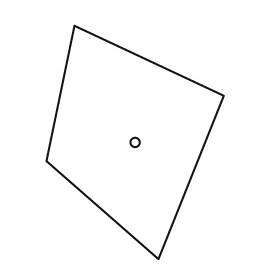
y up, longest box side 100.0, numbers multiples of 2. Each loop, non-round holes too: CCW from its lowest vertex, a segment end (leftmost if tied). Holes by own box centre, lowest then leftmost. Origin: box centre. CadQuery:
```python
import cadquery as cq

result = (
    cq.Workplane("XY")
    .moveTo(10.0, -50.0)
    .lineTo(38.0, 20.0)
    .lineTo(-26.0, 50.0)
    .lineTo(-38.0, -8.0)
    .close()
    .moveTo(0.0, 0.0)
    .circle(2.0)
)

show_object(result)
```